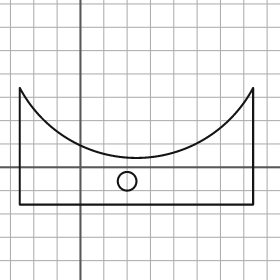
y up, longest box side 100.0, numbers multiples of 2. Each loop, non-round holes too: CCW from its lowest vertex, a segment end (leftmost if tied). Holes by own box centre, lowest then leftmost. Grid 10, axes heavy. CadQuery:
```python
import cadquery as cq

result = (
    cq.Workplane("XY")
    .moveTo(-26.0, -16.0)
    .lineTo(74.0, -16.0)
    .lineTo(74.0, 34.0)
    .threePointArc((24.0, 4.0), (-26.0, 34.0))
    .close()
    .moveTo(20.0, -6.0)
    .circle(4.0)
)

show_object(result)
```